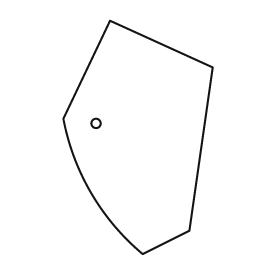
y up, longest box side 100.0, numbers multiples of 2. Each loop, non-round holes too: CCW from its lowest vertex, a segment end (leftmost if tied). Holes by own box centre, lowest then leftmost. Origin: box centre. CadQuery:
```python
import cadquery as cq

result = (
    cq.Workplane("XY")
    .moveTo(2.0, -50.0)
    .lineTo(22.0, -40.0)
    .lineTo(32.0, 30.0)
    .lineTo(-12.0, 50.0)
    .lineTo(-32.0, 8.0)
    .threePointArc((-20.0, -24.0), (2.0, -50.0))
    .close()
    .moveTo(-18.0, 6.0)
    .circle(2.0)
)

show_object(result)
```